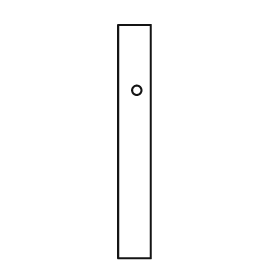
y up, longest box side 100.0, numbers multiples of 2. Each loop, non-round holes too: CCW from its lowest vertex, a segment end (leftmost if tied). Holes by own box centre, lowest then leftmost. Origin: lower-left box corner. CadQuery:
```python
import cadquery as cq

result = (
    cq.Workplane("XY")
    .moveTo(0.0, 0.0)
    .lineTo(14.0, 0.0)
    .lineTo(14.0, 100.0)
    .lineTo(0.0, 100.0)
    .close()
    .moveTo(8.0, 72.0)
    .circle(2.0)
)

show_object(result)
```